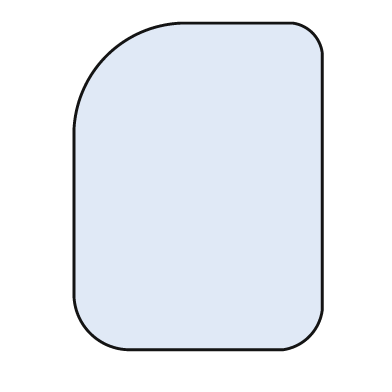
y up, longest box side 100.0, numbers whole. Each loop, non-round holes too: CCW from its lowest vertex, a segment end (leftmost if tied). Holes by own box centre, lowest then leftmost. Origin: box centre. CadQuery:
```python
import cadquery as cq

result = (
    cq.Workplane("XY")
    .moveTo(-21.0, -50.0)
    .lineTo(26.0, -50.0)
    .threePointArc((34.0, -46.0), (38.0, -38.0))
    .lineTo(38.0, 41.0)
    .threePointArc((35.0, 47.0), (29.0, 50.0))
    .lineTo(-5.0, 50.0)
    .threePointArc((-28.0, 40.0), (-38.0, 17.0))
    .lineTo(-38.0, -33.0)
    .threePointArc((-33.0, -45.0), (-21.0, -50.0))
    .close()
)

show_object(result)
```